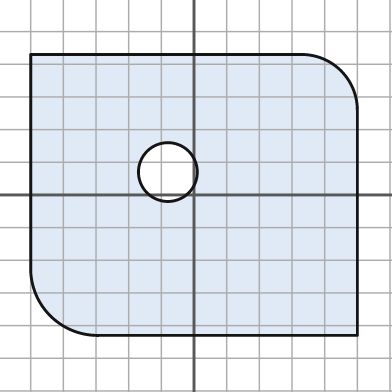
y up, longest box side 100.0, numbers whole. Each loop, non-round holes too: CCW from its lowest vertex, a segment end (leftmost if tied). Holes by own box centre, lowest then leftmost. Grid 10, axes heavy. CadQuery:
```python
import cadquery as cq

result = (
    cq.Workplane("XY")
    .moveTo(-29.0, -43.0)
    .lineTo(50.0, -43.0)
    .lineTo(50.0, 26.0)
    .threePointArc((45.0, 38.0), (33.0, 43.0))
    .lineTo(-50.0, 43.0)
    .lineTo(-50.0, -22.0)
    .threePointArc((-44.0, -37.0), (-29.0, -43.0))
    .close()
    .moveTo(-8.0, 7.0)
    .circle(9.0)
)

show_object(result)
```